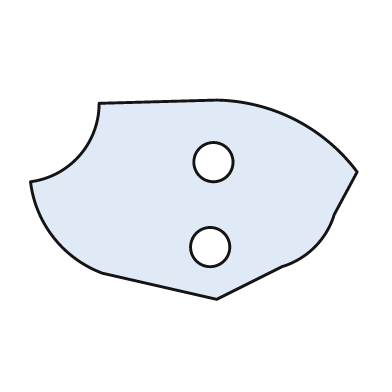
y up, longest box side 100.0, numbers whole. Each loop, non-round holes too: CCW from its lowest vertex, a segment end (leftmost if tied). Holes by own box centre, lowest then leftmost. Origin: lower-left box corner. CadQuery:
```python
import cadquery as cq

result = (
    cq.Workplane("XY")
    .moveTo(57.0, 0.0)
    .lineTo(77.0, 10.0)
    .threePointArc((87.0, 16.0), (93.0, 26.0))
    .lineTo(100.0, 39.0)
    .threePointArc((81.0, 55.0), (57.0, 61.0))
    .lineTo(21.0, 60.0)
    .threePointArc((15.0, 44.0), (0.0, 36.0))
    .threePointArc((7.0, 19.0), (22.0, 8.0))
    .close()
    .moveTo(55.0, 16.0)
    .circle(6.0)
    .moveTo(56.0, 42.0)
    .circle(6.0)
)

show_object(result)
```